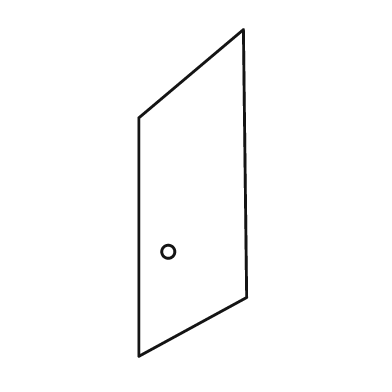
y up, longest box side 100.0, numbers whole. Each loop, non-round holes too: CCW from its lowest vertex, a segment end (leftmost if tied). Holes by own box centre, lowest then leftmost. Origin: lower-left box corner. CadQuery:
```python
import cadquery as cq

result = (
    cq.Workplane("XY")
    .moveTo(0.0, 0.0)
    .lineTo(33.0, 18.0)
    .lineTo(32.0, 100.0)
    .lineTo(0.0, 73.0)
    .close()
    .moveTo(9.0, 32.0)
    .circle(2.0)
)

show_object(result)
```